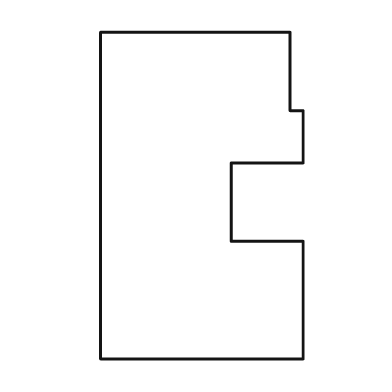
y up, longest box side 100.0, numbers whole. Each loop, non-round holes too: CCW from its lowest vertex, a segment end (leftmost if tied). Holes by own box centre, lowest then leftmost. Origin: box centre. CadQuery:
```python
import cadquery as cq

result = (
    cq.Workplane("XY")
    .moveTo(-31.0, -50.0)
    .lineTo(31.0, -50.0)
    .lineTo(31.0, -14.0)
    .lineTo(9.0, -14.0)
    .lineTo(9.0, 10.0)
    .lineTo(31.0, 10.0)
    .lineTo(31.0, 26.0)
    .lineTo(27.0, 26.0)
    .lineTo(27.0, 50.0)
    .lineTo(-31.0, 50.0)
    .close()
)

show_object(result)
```